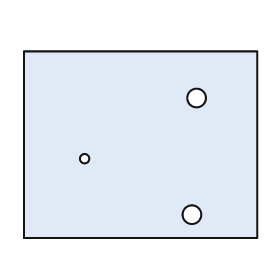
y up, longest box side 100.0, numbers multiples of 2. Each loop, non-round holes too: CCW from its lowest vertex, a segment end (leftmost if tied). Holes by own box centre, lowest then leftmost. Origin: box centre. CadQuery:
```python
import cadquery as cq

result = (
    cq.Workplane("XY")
    .moveTo(-50.0, -40.0)
    .lineTo(50.0, -40.0)
    .lineTo(50.0, 40.0)
    .lineTo(-50.0, 40.0)
    .close()
    .moveTo(22.0, -30.0)
    .circle(4.0)
    .moveTo(-24.0, -6.0)
    .circle(2.0)
    .moveTo(24.0, 20.0)
    .circle(4.0)
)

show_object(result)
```